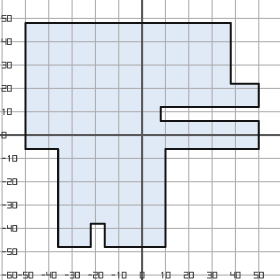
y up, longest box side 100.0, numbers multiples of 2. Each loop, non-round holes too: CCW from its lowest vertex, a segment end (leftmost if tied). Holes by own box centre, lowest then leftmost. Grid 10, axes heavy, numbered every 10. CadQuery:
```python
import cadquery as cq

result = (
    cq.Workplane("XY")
    .moveTo(-36.0, -48.0)
    .lineTo(-22.0, -48.0)
    .lineTo(-22.0, -38.0)
    .lineTo(-16.0, -38.0)
    .lineTo(-16.0, -48.0)
    .lineTo(10.0, -48.0)
    .lineTo(10.0, -6.0)
    .lineTo(50.0, -6.0)
    .lineTo(50.0, 6.0)
    .lineTo(8.0, 6.0)
    .lineTo(8.0, 12.0)
    .lineTo(50.0, 12.0)
    .lineTo(50.0, 22.0)
    .lineTo(38.0, 22.0)
    .lineTo(38.0, 48.0)
    .lineTo(-50.0, 48.0)
    .lineTo(-50.0, -6.0)
    .lineTo(-36.0, -6.0)
    .close()
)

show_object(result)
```